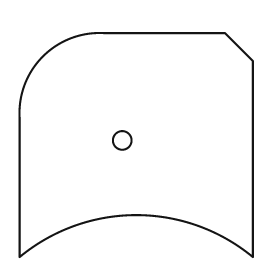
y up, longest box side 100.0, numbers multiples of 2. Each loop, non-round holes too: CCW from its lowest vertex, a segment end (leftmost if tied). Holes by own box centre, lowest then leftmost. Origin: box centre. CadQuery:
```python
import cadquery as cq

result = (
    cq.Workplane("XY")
    .moveTo(-50.0, -48.0)
    .threePointArc((0.0, -30.0), (50.0, -48.0))
    .lineTo(50.0, 36.0)
    .lineTo(38.0, 48.0)
    .lineTo(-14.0, 48.0)
    .threePointArc((-40.0, 38.0), (-50.0, 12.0))
    .close()
    .moveTo(-6.0, 2.0)
    .circle(4.0)
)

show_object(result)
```